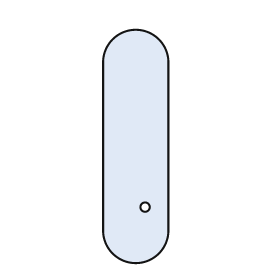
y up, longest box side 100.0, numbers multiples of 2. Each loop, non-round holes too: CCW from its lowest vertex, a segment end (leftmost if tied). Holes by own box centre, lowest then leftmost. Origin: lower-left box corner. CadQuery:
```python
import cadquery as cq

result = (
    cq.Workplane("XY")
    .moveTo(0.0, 14.0)
    .threePointArc((14.0, 0.0), (28.0, 14.0))
    .lineTo(28.0, 86.0)
    .threePointArc((14.0, 100.0), (0.0, 86.0))
    .close()
    .moveTo(18.0, 24.0)
    .circle(2.0)
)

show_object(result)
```